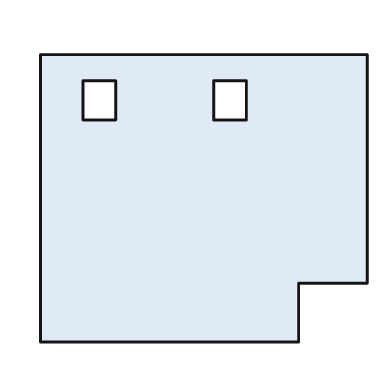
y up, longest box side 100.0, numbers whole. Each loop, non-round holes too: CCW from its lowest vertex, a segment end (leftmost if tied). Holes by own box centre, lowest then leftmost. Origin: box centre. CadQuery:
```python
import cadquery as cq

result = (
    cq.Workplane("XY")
    .moveTo(-50.0, -44.0)
    .lineTo(29.0, -44.0)
    .lineTo(29.0, -26.0)
    .lineTo(50.0, -26.0)
    .lineTo(50.0, 44.0)
    .lineTo(-50.0, 44.0)
    .close()
    .moveTo(-37.0, 24.0)
    .lineTo(-27.0, 24.0)
    .lineTo(-27.0, 36.0)
    .lineTo(-37.0, 36.0)
    .close()
    .moveTo(3.0, 24.0)
    .lineTo(13.0, 24.0)
    .lineTo(13.0, 36.0)
    .lineTo(3.0, 36.0)
    .close()
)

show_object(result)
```